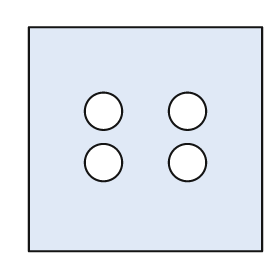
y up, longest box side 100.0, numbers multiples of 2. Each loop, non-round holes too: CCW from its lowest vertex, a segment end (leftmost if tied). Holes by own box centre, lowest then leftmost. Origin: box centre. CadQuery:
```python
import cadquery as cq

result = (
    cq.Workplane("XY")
    .moveTo(-50.0, -48.0)
    .lineTo(50.0, -48.0)
    .lineTo(50.0, 48.0)
    .lineTo(-50.0, 48.0)
    .close()
    .moveTo(-18.0, -10.0)
    .circle(8.0)
    .moveTo(18.0, -10.0)
    .circle(8.0)
    .moveTo(-18.0, 12.0)
    .circle(8.0)
    .moveTo(18.0, 12.0)
    .circle(8.0)
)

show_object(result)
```